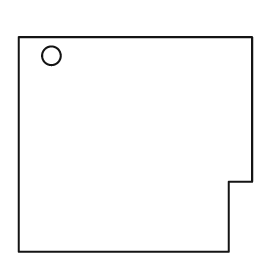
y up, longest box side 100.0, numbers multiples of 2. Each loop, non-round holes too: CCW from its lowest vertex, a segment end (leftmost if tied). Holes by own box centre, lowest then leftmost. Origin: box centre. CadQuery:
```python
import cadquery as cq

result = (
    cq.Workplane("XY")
    .moveTo(-50.0, -46.0)
    .lineTo(40.0, -46.0)
    .lineTo(40.0, -16.0)
    .lineTo(50.0, -16.0)
    .lineTo(50.0, 46.0)
    .lineTo(-50.0, 46.0)
    .close()
    .moveTo(-36.0, 38.0)
    .circle(4.0)
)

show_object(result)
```